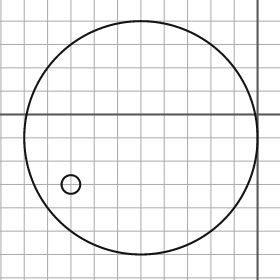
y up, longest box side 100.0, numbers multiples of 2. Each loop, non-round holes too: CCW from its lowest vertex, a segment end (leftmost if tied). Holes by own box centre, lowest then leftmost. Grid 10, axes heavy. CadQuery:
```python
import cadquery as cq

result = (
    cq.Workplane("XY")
    .moveTo(-50.0, -10.0)
    .circle(50.0)
    .moveTo(-80.0, -30.0)
    .circle(4.0)
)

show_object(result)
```